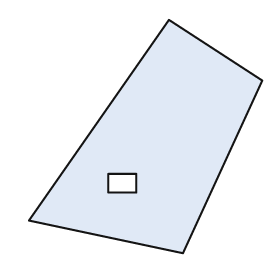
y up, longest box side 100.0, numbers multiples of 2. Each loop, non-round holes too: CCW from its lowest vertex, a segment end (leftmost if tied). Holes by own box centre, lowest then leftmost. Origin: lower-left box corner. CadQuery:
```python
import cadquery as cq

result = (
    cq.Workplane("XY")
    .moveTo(66.0, 0.0)
    .lineTo(100.0, 74.0)
    .lineTo(60.0, 100.0)
    .lineTo(0.0, 14.0)
    .close()
    .moveTo(34.0, 26.0)
    .lineTo(46.0, 26.0)
    .lineTo(46.0, 34.0)
    .lineTo(34.0, 34.0)
    .close()
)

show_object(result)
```